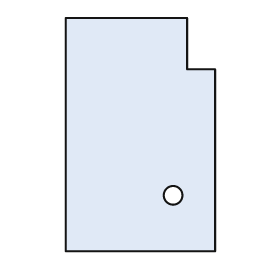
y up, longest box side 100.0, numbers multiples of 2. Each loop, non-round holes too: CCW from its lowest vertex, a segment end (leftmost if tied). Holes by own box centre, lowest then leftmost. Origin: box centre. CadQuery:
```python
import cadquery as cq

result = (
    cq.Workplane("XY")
    .moveTo(-32.0, -50.0)
    .lineTo(32.0, -50.0)
    .lineTo(32.0, 28.0)
    .lineTo(20.0, 28.0)
    .lineTo(20.0, 50.0)
    .lineTo(-32.0, 50.0)
    .close()
    .moveTo(14.0, -26.0)
    .circle(4.0)
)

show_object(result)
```